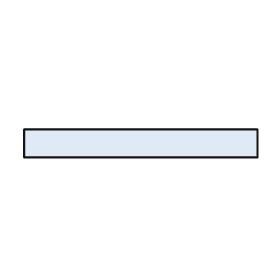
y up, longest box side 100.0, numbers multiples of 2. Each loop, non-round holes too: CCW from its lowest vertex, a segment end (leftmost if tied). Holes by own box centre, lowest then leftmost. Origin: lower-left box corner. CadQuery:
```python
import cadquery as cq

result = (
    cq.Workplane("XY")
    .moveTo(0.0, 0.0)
    .lineTo(100.0, 0.0)
    .lineTo(100.0, 12.0)
    .lineTo(0.0, 12.0)
    .close()
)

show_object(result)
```